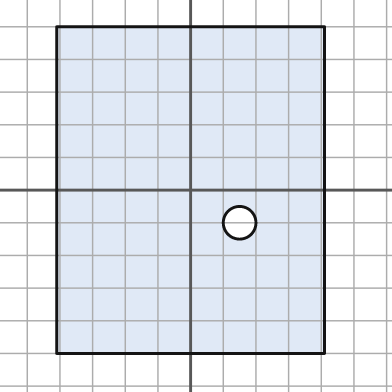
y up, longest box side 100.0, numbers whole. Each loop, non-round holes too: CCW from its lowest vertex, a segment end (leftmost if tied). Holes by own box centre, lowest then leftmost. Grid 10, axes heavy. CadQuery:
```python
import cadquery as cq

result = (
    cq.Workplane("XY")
    .moveTo(-41.0, -50.0)
    .lineTo(41.0, -50.0)
    .lineTo(41.0, 50.0)
    .lineTo(-41.0, 50.0)
    .close()
    .moveTo(15.0, -10.0)
    .circle(5.0)
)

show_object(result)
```